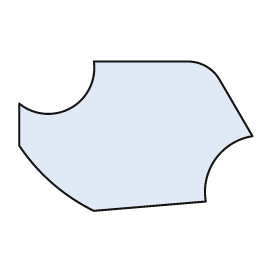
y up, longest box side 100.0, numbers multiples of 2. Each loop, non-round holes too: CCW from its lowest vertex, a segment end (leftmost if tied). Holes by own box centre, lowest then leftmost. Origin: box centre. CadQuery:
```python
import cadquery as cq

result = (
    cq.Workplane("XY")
    .moveTo(-18.0, -32.0)
    .lineTo(30.0, -28.0)
    .threePointArc((34.0, -10.0), (50.0, 0.0))
    .lineTo(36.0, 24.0)
    .threePointArc((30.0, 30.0), (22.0, 32.0))
    .lineTo(-18.0, 32.0)
    .threePointArc((-28.0, 12.0), (-50.0, 14.0))
    .lineTo(-50.0, -4.0)
    .threePointArc((-36.0, -20.0), (-18.0, -32.0))
    .close()
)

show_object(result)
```